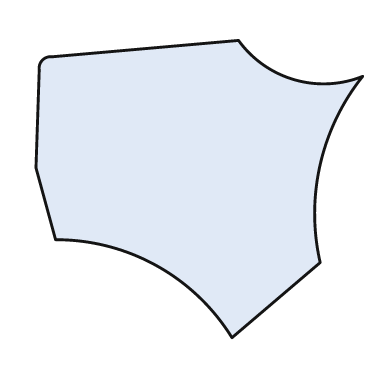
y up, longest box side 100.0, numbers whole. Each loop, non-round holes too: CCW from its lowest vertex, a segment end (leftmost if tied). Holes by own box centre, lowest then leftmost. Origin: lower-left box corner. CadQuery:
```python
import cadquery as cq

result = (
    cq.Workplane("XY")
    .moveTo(60.0, 0.0)
    .lineTo(87.0, 23.0)
    .threePointArc((87.0, 53.0), (100.0, 80.0))
    .threePointArc((79.0, 79.0), (62.0, 91.0))
    .lineTo(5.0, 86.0)
    .threePointArc((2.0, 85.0), (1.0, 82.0))
    .lineTo(0.0, 52.0)
    .lineTo(6.0, 30.0)
    .threePointArc((37.0, 22.0), (60.0, 0.0))
    .close()
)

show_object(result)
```